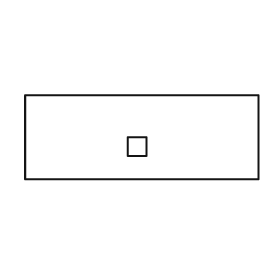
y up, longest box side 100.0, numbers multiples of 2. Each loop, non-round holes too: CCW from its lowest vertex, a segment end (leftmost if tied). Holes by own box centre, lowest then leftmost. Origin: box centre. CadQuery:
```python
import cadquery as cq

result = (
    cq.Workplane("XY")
    .moveTo(-50.0, -18.0)
    .lineTo(50.0, -18.0)
    .lineTo(50.0, 18.0)
    .lineTo(-50.0, 18.0)
    .close()
    .moveTo(-6.0, -8.0)
    .lineTo(2.0, -8.0)
    .lineTo(2.0, 0.0)
    .lineTo(-6.0, 0.0)
    .close()
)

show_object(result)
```